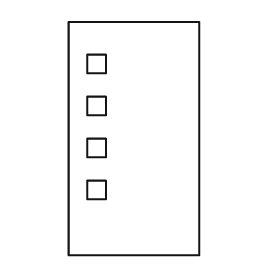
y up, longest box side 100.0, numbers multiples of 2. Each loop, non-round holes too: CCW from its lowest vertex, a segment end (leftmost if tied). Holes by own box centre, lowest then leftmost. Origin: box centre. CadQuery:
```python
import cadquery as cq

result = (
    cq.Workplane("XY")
    .moveTo(-28.0, -50.0)
    .lineTo(28.0, -50.0)
    .lineTo(28.0, 50.0)
    .lineTo(-28.0, 50.0)
    .close()
    .moveTo(-20.0, -26.0)
    .lineTo(-12.0, -26.0)
    .lineTo(-12.0, -18.0)
    .lineTo(-20.0, -18.0)
    .close()
    .moveTo(-20.0, -8.0)
    .lineTo(-12.0, -8.0)
    .lineTo(-12.0, 0.0)
    .lineTo(-20.0, 0.0)
    .close()
    .moveTo(-20.0, 10.0)
    .lineTo(-12.0, 10.0)
    .lineTo(-12.0, 18.0)
    .lineTo(-20.0, 18.0)
    .close()
    .moveTo(-20.0, 28.0)
    .lineTo(-12.0, 28.0)
    .lineTo(-12.0, 36.0)
    .lineTo(-20.0, 36.0)
    .close()
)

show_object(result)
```